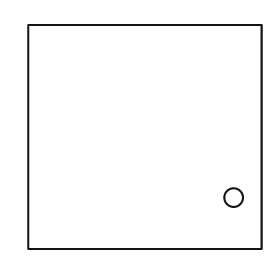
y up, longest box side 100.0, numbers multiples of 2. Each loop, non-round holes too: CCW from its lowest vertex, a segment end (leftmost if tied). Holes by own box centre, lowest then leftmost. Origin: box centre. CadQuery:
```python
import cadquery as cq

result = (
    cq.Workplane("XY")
    .moveTo(-50.0, -48.0)
    .lineTo(50.0, -48.0)
    .lineTo(50.0, 48.0)
    .lineTo(-50.0, 48.0)
    .close()
    .moveTo(38.0, -26.0)
    .circle(4.0)
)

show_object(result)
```